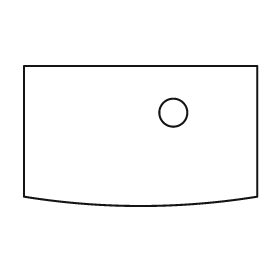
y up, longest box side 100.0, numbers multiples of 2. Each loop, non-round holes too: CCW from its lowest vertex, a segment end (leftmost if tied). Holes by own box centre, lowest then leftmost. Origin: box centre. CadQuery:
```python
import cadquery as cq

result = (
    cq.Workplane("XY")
    .moveTo(-50.0, -26.0)
    .threePointArc((0.0, -30.0), (50.0, -26.0))
    .lineTo(50.0, 30.0)
    .lineTo(-50.0, 30.0)
    .close()
    .moveTo(14.0, 10.0)
    .circle(6.0)
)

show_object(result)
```